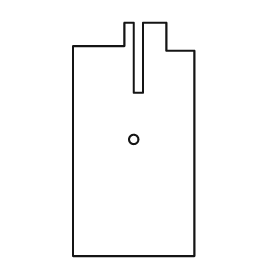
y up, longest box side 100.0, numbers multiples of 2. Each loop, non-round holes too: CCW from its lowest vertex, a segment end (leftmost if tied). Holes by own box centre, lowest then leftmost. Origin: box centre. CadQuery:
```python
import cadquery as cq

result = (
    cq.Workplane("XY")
    .moveTo(-26.0, -50.0)
    .lineTo(26.0, -50.0)
    .lineTo(26.0, 38.0)
    .lineTo(14.0, 38.0)
    .lineTo(14.0, 50.0)
    .lineTo(4.0, 50.0)
    .lineTo(4.0, 20.0)
    .lineTo(0.0, 20.0)
    .lineTo(0.0, 50.0)
    .lineTo(-4.0, 50.0)
    .lineTo(-4.0, 40.0)
    .lineTo(-26.0, 40.0)
    .close()
    .moveTo(0.0, 0.0)
    .circle(2.0)
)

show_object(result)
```